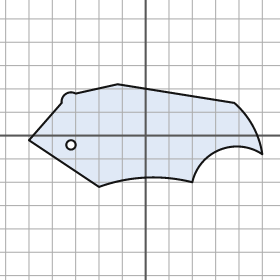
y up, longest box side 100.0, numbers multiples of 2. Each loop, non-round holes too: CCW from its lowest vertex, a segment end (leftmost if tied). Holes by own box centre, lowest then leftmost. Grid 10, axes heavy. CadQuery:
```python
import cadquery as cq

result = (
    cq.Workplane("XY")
    .moveTo(-20.0, -22.0)
    .threePointArc((0.0, -18.0), (20.0, -20.0))
    .threePointArc((32.0, -6.0), (50.0, -8.0))
    .threePointArc((46.0, 4.0), (38.0, 14.0))
    .lineTo(-12.0, 22.0)
    .lineTo(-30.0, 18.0)
    .threePointArc((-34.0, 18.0), (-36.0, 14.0))
    .lineTo(-50.0, -2.0)
    .close()
    .moveTo(-32.0, -4.0)
    .circle(2.0)
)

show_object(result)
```